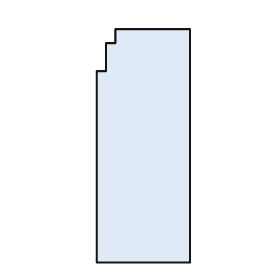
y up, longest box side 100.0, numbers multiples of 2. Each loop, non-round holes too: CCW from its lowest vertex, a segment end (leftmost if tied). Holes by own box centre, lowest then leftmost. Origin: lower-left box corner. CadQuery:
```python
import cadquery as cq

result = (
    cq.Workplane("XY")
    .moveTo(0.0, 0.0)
    .lineTo(40.0, 0.0)
    .lineTo(40.0, 100.0)
    .lineTo(8.0, 100.0)
    .lineTo(8.0, 94.0)
    .lineTo(4.0, 94.0)
    .lineTo(4.0, 82.0)
    .lineTo(0.0, 82.0)
    .close()
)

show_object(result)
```